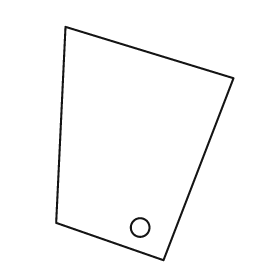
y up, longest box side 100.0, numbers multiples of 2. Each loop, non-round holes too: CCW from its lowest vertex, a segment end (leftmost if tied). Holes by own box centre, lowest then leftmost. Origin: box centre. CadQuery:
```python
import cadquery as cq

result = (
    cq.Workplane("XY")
    .moveTo(8.0, -50.0)
    .lineTo(38.0, 28.0)
    .lineTo(-34.0, 50.0)
    .lineTo(-38.0, -34.0)
    .close()
    .moveTo(-2.0, -36.0)
    .circle(4.0)
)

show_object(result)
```